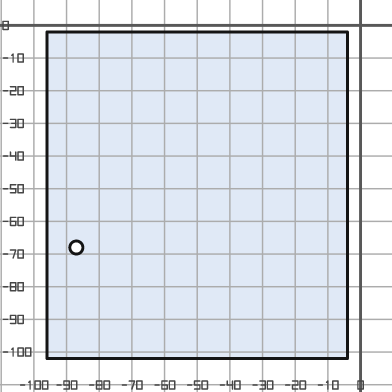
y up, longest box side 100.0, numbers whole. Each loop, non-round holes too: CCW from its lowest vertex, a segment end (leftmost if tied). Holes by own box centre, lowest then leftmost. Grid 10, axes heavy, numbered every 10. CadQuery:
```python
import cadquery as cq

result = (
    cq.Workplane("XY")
    .moveTo(-96.0, -102.0)
    .lineTo(-4.0, -102.0)
    .lineTo(-4.0, -2.0)
    .lineTo(-96.0, -2.0)
    .close()
    .moveTo(-87.0, -68.0)
    .circle(2.0)
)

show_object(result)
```